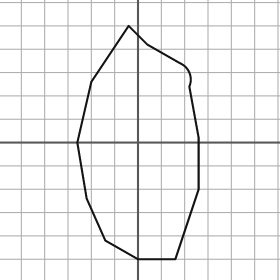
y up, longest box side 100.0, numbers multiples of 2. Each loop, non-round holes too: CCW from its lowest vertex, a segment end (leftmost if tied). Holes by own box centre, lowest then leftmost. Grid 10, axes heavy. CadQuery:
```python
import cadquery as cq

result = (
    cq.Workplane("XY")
    .moveTo(0.0, -50.0)
    .lineTo(16.0, -50.0)
    .lineTo(26.0, -20.0)
    .lineTo(26.0, 2.0)
    .lineTo(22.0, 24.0)
    .threePointArc((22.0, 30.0), (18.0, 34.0))
    .lineTo(4.0, 42.0)
    .lineTo(-4.0, 50.0)
    .lineTo(-20.0, 26.0)
    .lineTo(-26.0, 0.0)
    .lineTo(-22.0, -24.0)
    .lineTo(-14.0, -42.0)
    .close()
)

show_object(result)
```